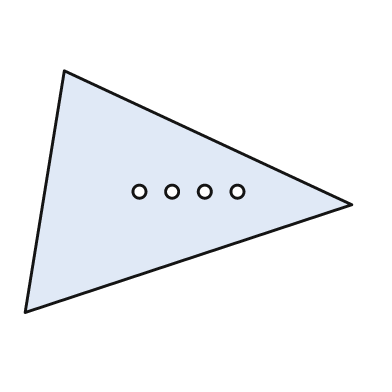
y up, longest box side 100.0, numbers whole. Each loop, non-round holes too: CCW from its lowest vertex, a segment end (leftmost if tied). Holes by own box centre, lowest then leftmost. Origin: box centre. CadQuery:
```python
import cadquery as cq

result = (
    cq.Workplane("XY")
    .moveTo(-50.0, -37.0)
    .lineTo(50.0, -4.0)
    .lineTo(-38.0, 37.0)
    .close()
    .moveTo(-15.0, 0.0)
    .circle(2.0)
    .moveTo(-5.0, 0.0)
    .circle(2.0)
    .moveTo(5.0, 0.0)
    .circle(2.0)
    .moveTo(15.0, 0.0)
    .circle(2.0)
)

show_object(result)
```